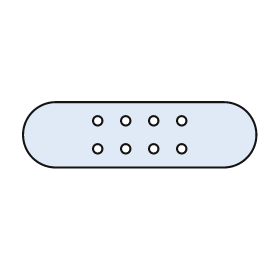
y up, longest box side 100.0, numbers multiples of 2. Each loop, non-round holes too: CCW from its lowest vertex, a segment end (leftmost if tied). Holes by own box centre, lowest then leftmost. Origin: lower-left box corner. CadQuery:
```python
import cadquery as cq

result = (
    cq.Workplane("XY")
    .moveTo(14.0, 0.0)
    .lineTo(86.0, 0.0)
    .threePointArc((100.0, 14.0), (86.0, 28.0))
    .lineTo(14.0, 28.0)
    .threePointArc((0.0, 14.0), (14.0, 0.0))
    .close()
    .moveTo(32.0, 8.0)
    .circle(2.0)
    .moveTo(44.0, 8.0)
    .circle(2.0)
    .moveTo(56.0, 8.0)
    .circle(2.0)
    .moveTo(68.0, 8.0)
    .circle(2.0)
    .moveTo(32.0, 20.0)
    .circle(2.0)
    .moveTo(44.0, 20.0)
    .circle(2.0)
    .moveTo(56.0, 20.0)
    .circle(2.0)
    .moveTo(68.0, 20.0)
    .circle(2.0)
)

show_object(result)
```